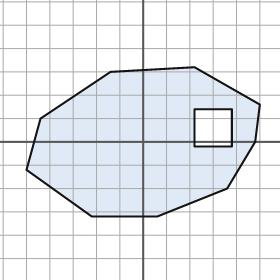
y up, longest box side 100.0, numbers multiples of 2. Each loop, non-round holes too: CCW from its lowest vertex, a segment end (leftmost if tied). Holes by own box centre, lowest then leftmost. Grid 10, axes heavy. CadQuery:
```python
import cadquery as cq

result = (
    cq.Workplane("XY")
    .moveTo(-22.0, -32.0)
    .lineTo(6.0, -32.0)
    .lineTo(36.0, -20.0)
    .lineTo(48.0, 0.0)
    .lineTo(50.0, 16.0)
    .lineTo(22.0, 32.0)
    .lineTo(-14.0, 30.0)
    .lineTo(-44.0, 10.0)
    .lineTo(-50.0, -12.0)
    .close()
    .moveTo(22.0, -2.0)
    .lineTo(38.0, -2.0)
    .lineTo(38.0, 14.0)
    .lineTo(22.0, 14.0)
    .close()
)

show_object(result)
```